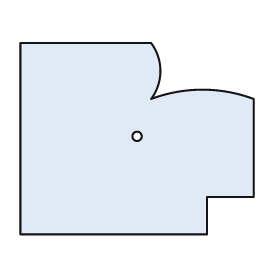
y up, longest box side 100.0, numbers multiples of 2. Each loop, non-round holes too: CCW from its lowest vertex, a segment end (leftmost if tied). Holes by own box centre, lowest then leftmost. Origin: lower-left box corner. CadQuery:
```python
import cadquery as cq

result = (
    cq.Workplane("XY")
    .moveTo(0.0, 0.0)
    .lineTo(80.0, 0.0)
    .lineTo(80.0, 16.0)
    .lineTo(100.0, 16.0)
    .lineTo(100.0, 58.0)
    .threePointArc((78.0, 62.0), (56.0, 58.0))
    .threePointArc((60.0, 70.0), (56.0, 82.0))
    .lineTo(0.0, 82.0)
    .close()
    .moveTo(50.0, 42.0)
    .circle(2.0)
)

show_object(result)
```